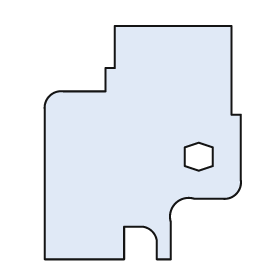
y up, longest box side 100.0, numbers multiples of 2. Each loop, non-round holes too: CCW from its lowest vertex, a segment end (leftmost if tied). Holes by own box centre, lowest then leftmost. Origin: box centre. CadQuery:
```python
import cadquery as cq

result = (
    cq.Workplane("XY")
    .moveTo(-42.0, -50.0)
    .lineTo(-8.0, -50.0)
    .lineTo(-8.0, -36.0)
    .lineTo(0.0, -36.0)
    .threePointArc((4.0, -38.0), (6.0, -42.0))
    .lineTo(6.0, -50.0)
    .lineTo(12.0, -50.0)
    .lineTo(12.0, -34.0)
    .threePointArc((14.0, -26.0), (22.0, -24.0))
    .lineTo(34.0, -24.0)
    .threePointArc((40.0, -22.0), (42.0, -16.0))
    .lineTo(42.0, 12.0)
    .lineTo(38.0, 12.0)
    .lineTo(38.0, 50.0)
    .lineTo(-12.0, 50.0)
    .lineTo(-12.0, 32.0)
    .lineTo(-16.0, 32.0)
    .lineTo(-16.0, 22.0)
    .lineTo(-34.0, 22.0)
    .threePointArc((-40.0, 20.0), (-42.0, 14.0))
    .close()
    .moveTo(24.0, -12.0)
    .lineTo(30.0, -10.0)
    .lineTo(30.0, -2.0)
    .lineTo(24.0, 0.0)
    .lineTo(18.0, -2.0)
    .lineTo(18.0, -10.0)
    .close()
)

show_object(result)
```